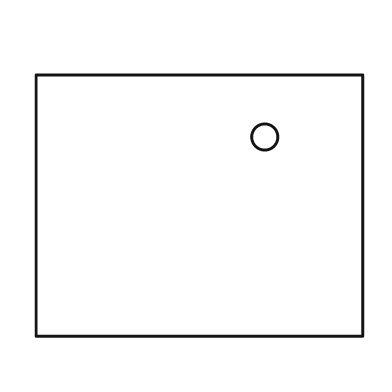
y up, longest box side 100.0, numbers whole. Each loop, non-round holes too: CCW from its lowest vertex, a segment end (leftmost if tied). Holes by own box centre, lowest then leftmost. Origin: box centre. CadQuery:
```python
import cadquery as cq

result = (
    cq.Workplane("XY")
    .moveTo(-50.0, -40.0)
    .lineTo(50.0, -40.0)
    .lineTo(50.0, 40.0)
    .lineTo(-50.0, 40.0)
    .close()
    .moveTo(20.0, 21.0)
    .circle(4.0)
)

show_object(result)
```